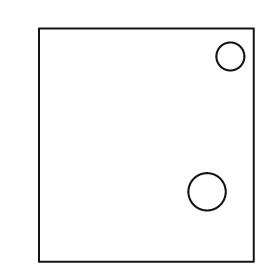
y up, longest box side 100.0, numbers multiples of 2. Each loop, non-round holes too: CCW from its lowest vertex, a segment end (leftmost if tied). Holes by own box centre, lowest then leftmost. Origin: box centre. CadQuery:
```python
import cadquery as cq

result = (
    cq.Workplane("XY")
    .moveTo(-46.0, -50.0)
    .lineTo(46.0, -50.0)
    .lineTo(46.0, 50.0)
    .lineTo(-46.0, 50.0)
    .close()
    .moveTo(26.0, -20.0)
    .circle(8.0)
    .moveTo(36.0, 38.0)
    .circle(6.0)
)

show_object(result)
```